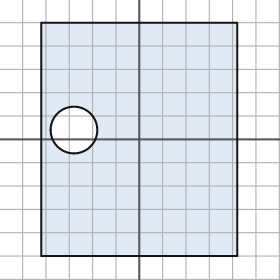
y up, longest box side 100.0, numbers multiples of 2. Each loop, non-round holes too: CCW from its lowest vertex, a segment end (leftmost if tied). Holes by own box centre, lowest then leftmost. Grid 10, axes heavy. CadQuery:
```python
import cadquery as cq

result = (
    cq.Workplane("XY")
    .moveTo(-42.0, -50.0)
    .lineTo(42.0, -50.0)
    .lineTo(42.0, 50.0)
    .lineTo(-42.0, 50.0)
    .close()
    .moveTo(-28.0, 4.0)
    .circle(10.0)
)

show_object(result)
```